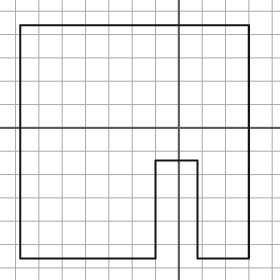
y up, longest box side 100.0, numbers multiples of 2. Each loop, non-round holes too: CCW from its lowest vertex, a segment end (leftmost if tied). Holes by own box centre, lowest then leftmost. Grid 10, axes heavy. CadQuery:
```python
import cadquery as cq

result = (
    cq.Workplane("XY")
    .moveTo(-68.0, -56.0)
    .lineTo(-10.0, -56.0)
    .lineTo(-10.0, -14.0)
    .lineTo(8.0, -14.0)
    .lineTo(8.0, -56.0)
    .lineTo(30.0, -56.0)
    .lineTo(30.0, 44.0)
    .lineTo(-68.0, 44.0)
    .close()
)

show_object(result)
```